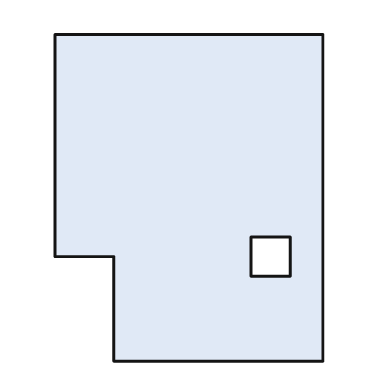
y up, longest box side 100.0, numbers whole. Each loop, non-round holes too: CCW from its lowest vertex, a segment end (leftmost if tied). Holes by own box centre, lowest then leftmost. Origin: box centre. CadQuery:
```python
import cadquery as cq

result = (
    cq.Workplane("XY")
    .moveTo(-23.0, -50.0)
    .lineTo(41.0, -50.0)
    .lineTo(41.0, 50.0)
    .lineTo(-41.0, 50.0)
    .lineTo(-41.0, -18.0)
    .lineTo(-23.0, -18.0)
    .close()
    .moveTo(19.0, -24.0)
    .lineTo(31.0, -24.0)
    .lineTo(31.0, -12.0)
    .lineTo(19.0, -12.0)
    .close()
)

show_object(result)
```